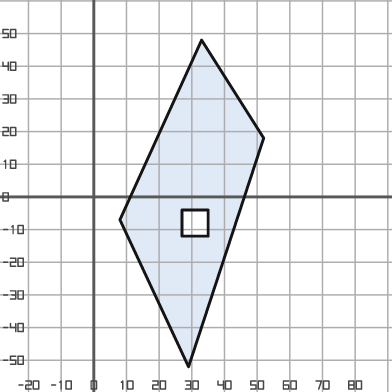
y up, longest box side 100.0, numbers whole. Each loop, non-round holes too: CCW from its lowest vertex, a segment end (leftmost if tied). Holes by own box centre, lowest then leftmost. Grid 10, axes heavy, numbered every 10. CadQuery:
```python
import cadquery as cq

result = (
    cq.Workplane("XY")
    .moveTo(29.0, -52.0)
    .lineTo(52.0, 18.0)
    .lineTo(33.0, 48.0)
    .lineTo(8.0, -7.0)
    .close()
    .moveTo(27.0, -12.0)
    .lineTo(35.0, -12.0)
    .lineTo(35.0, -4.0)
    .lineTo(27.0, -4.0)
    .close()
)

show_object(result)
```